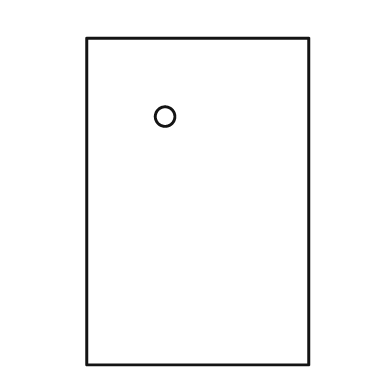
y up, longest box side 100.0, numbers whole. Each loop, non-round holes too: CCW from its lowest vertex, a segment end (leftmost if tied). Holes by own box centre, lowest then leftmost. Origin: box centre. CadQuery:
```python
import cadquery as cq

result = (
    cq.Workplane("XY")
    .moveTo(-34.0, -50.0)
    .lineTo(34.0, -50.0)
    .lineTo(34.0, 50.0)
    .lineTo(-34.0, 50.0)
    .close()
    .moveTo(-10.0, 26.0)
    .circle(3.0)
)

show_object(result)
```